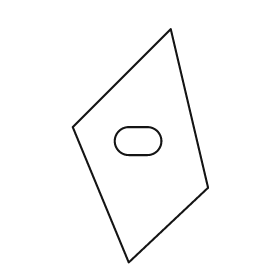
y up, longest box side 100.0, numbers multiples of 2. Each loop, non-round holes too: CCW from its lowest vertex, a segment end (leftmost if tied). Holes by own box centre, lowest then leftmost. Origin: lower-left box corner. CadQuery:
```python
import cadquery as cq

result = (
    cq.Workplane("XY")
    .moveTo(24.0, 0.0)
    .lineTo(58.0, 32.0)
    .lineTo(42.0, 100.0)
    .lineTo(0.0, 58.0)
    .close()
    .moveTo(24.0, 46.0)
    .lineTo(32.0, 46.0)
    .threePointArc((38.0, 52.0), (32.0, 58.0))
    .lineTo(24.0, 58.0)
    .threePointArc((18.0, 52.0), (24.0, 46.0))
    .close()
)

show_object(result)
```